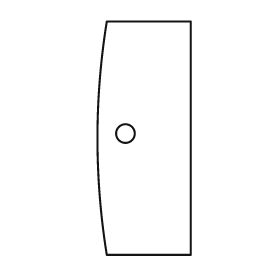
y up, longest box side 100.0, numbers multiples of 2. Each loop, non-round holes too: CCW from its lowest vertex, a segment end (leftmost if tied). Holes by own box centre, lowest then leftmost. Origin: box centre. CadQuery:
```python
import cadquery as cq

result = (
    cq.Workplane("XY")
    .moveTo(-16.0, -50.0)
    .lineTo(20.0, -50.0)
    .lineTo(20.0, 50.0)
    .lineTo(-16.0, 50.0)
    .threePointArc((-20.0, 0.0), (-16.0, -50.0))
    .close()
    .moveTo(-8.0, 2.0)
    .circle(4.0)
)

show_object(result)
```